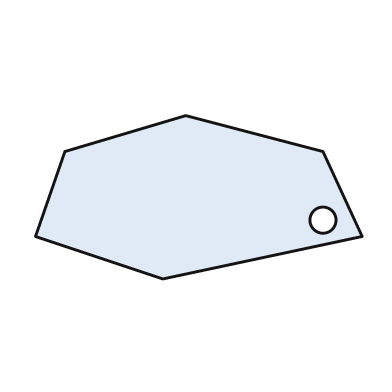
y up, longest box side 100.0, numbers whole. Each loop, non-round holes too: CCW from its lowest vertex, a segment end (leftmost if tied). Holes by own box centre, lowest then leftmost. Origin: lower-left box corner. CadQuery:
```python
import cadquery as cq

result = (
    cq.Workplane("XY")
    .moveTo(39.0, 0.0)
    .lineTo(100.0, 13.0)
    .lineTo(88.0, 39.0)
    .lineTo(46.0, 50.0)
    .lineTo(9.0, 39.0)
    .lineTo(0.0, 13.0)
    .close()
    .moveTo(88.0, 18.0)
    .circle(4.0)
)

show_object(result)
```